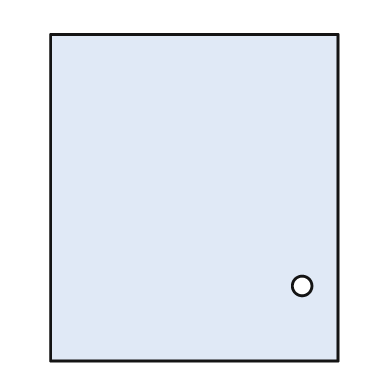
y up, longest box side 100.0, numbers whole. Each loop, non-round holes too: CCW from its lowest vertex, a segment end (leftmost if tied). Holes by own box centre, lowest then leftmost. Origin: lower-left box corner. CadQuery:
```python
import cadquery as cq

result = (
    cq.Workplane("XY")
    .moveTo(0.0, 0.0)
    .lineTo(88.0, 0.0)
    .lineTo(88.0, 100.0)
    .lineTo(0.0, 100.0)
    .close()
    .moveTo(77.0, 23.0)
    .circle(3.0)
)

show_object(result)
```